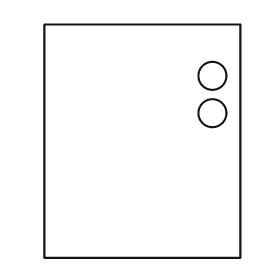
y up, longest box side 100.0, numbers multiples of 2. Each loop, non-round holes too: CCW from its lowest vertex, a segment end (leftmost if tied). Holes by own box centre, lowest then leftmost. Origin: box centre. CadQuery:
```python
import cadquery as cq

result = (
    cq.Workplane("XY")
    .moveTo(-42.0, -50.0)
    .lineTo(42.0, -50.0)
    .lineTo(42.0, 50.0)
    .lineTo(-42.0, 50.0)
    .close()
    .moveTo(30.0, 12.0)
    .circle(6.0)
    .moveTo(30.0, 28.0)
    .circle(6.0)
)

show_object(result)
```